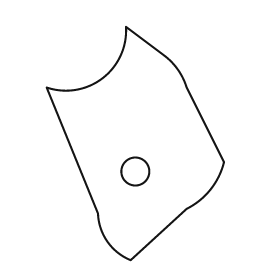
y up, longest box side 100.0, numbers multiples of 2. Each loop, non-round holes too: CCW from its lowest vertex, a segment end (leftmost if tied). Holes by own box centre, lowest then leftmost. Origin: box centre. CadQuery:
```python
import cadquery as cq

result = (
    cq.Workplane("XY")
    .moveTo(-2.0, -50.0)
    .lineTo(22.0, -28.0)
    .threePointArc((32.0, -20.0), (38.0, -8.0))
    .lineTo(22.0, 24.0)
    .threePointArc((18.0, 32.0), (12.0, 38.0))
    .lineTo(-4.0, 50.0)
    .threePointArc((-14.0, 28.0), (-38.0, 24.0))
    .lineTo(-16.0, -30.0)
    .threePointArc((-12.0, -42.0), (-2.0, -50.0))
    .close()
    .moveTo(0.0, -12.0)
    .circle(6.0)
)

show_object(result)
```